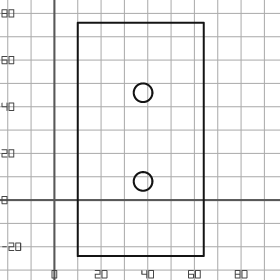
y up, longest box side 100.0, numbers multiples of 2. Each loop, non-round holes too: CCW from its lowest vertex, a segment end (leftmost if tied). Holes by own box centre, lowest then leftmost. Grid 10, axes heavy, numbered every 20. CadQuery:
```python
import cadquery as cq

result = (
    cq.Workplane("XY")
    .moveTo(10.0, -24.0)
    .lineTo(64.0, -24.0)
    .lineTo(64.0, 76.0)
    .lineTo(10.0, 76.0)
    .close()
    .moveTo(38.0, 8.0)
    .circle(4.0)
    .moveTo(38.0, 46.0)
    .circle(4.0)
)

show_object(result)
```